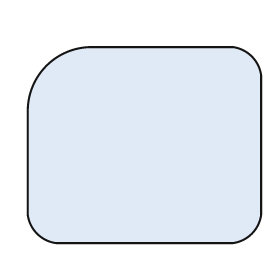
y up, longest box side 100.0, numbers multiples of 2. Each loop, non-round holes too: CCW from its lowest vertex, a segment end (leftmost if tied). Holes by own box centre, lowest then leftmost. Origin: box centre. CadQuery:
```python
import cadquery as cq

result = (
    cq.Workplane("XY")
    .moveTo(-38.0, -42.0)
    .lineTo(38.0, -42.0)
    .threePointArc((46.0, -38.0), (50.0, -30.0))
    .lineTo(50.0, 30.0)
    .threePointArc((46.0, 38.0), (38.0, 42.0))
    .lineTo(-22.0, 42.0)
    .threePointArc((-42.0, 34.0), (-50.0, 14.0))
    .lineTo(-50.0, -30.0)
    .threePointArc((-46.0, -38.0), (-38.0, -42.0))
    .close()
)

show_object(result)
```